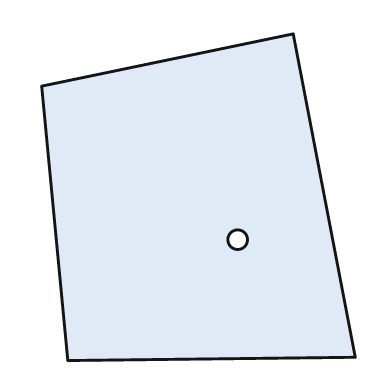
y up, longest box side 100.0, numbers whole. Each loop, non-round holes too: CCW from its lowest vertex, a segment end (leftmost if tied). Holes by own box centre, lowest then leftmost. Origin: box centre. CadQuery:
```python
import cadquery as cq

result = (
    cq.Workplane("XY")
    .moveTo(-40.0, -50.0)
    .lineTo(48.0, -49.0)
    .lineTo(29.0, 50.0)
    .lineTo(-48.0, 34.0)
    .close()
    .moveTo(12.0, -13.0)
    .circle(3.0)
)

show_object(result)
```